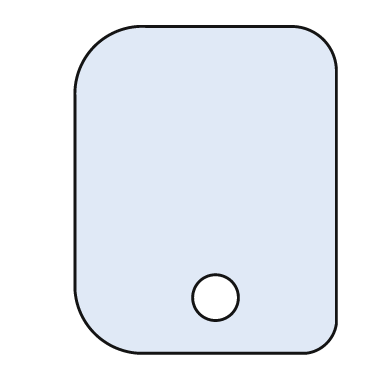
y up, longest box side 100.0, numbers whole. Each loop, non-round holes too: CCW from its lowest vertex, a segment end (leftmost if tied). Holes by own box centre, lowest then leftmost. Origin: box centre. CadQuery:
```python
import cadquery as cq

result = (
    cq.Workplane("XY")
    .moveTo(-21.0, -50.0)
    .lineTo(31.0, -50.0)
    .threePointArc((37.0, -47.0), (40.0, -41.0))
    .lineTo(40.0, 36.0)
    .threePointArc((36.0, 46.0), (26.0, 50.0))
    .lineTo(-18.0, 50.0)
    .threePointArc((-34.0, 44.0), (-40.0, 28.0))
    .lineTo(-40.0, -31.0)
    .threePointArc((-34.0, -44.0), (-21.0, -50.0))
    .close()
    .moveTo(3.0, -33.0)
    .circle(7.0)
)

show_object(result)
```